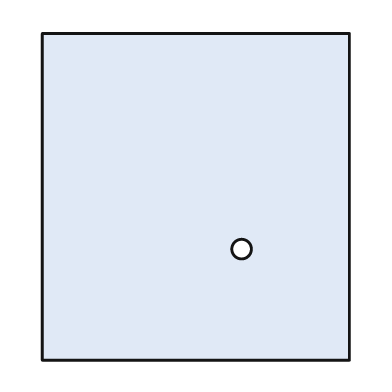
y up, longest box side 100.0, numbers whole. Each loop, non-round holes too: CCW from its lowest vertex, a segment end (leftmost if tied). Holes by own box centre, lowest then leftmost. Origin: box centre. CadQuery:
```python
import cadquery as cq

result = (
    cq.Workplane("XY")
    .moveTo(-47.0, -50.0)
    .lineTo(47.0, -50.0)
    .lineTo(47.0, 50.0)
    .lineTo(-47.0, 50.0)
    .close()
    .moveTo(14.0, -16.0)
    .circle(3.0)
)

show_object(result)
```